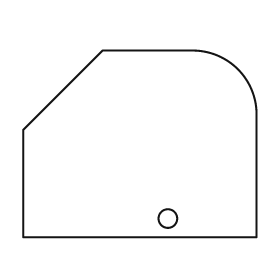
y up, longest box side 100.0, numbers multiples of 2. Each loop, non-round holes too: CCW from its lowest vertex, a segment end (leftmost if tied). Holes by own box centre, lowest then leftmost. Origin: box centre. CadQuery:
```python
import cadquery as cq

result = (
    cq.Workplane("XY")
    .moveTo(-50.0, -40.0)
    .lineTo(50.0, -40.0)
    .lineTo(50.0, 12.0)
    .threePointArc((42.0, 32.0), (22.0, 40.0))
    .lineTo(-16.0, 40.0)
    .lineTo(-50.0, 6.0)
    .close()
    .moveTo(12.0, -32.0)
    .circle(4.0)
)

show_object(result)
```